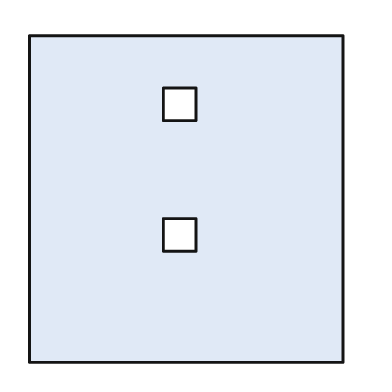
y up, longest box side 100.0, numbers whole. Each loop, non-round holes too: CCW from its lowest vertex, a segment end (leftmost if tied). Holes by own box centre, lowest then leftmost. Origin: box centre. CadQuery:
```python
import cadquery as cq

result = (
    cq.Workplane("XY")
    .moveTo(-48.0, -50.0)
    .lineTo(48.0, -50.0)
    .lineTo(48.0, 50.0)
    .lineTo(-48.0, 50.0)
    .close()
    .moveTo(-7.0, -16.0)
    .lineTo(3.0, -16.0)
    .lineTo(3.0, -6.0)
    .lineTo(-7.0, -6.0)
    .close()
    .moveTo(-7.0, 24.0)
    .lineTo(3.0, 24.0)
    .lineTo(3.0, 34.0)
    .lineTo(-7.0, 34.0)
    .close()
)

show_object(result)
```